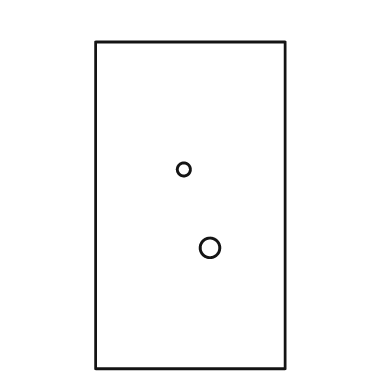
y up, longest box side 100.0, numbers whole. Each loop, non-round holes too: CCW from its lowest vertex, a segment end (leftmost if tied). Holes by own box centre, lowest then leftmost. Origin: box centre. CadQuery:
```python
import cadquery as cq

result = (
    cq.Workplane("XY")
    .moveTo(-29.0, -50.0)
    .lineTo(29.0, -50.0)
    .lineTo(29.0, 50.0)
    .lineTo(-29.0, 50.0)
    .close()
    .moveTo(6.0, -13.0)
    .circle(3.0)
    .moveTo(-2.0, 11.0)
    .circle(2.0)
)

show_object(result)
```